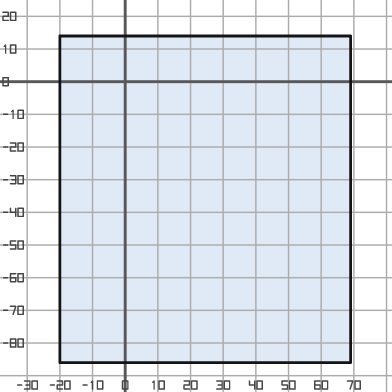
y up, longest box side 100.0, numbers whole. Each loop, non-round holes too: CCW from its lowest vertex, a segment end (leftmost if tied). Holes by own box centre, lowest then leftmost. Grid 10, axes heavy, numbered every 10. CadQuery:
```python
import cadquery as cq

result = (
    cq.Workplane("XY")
    .moveTo(-20.0, -86.0)
    .lineTo(69.0, -86.0)
    .lineTo(69.0, 14.0)
    .lineTo(-20.0, 14.0)
    .close()
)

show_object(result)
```